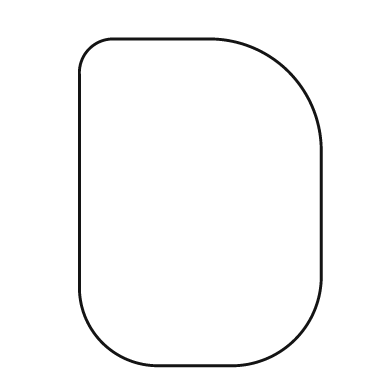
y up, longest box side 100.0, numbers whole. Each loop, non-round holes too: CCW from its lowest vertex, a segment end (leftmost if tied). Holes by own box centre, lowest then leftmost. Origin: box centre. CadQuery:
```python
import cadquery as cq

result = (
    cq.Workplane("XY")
    .moveTo(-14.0, -50.0)
    .lineTo(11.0, -50.0)
    .threePointArc((29.0, -42.0), (37.0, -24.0))
    .lineTo(37.0, 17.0)
    .threePointArc((27.0, 40.0), (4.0, 50.0))
    .lineTo(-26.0, 50.0)
    .threePointArc((-34.0, 47.0), (-37.0, 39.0))
    .lineTo(-37.0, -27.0)
    .threePointArc((-30.0, -43.0), (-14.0, -50.0))
    .close()
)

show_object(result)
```